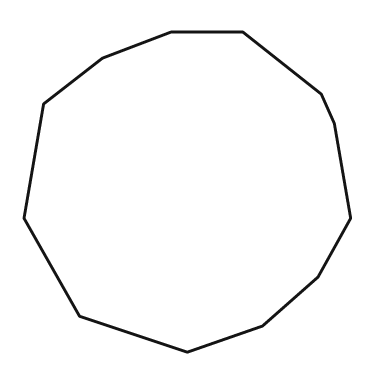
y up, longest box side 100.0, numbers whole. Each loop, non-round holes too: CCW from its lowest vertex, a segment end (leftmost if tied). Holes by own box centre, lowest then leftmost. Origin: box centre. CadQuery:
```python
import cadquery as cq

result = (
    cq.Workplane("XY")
    .moveTo(0.0, -49.0)
    .lineTo(23.0, -41.0)
    .lineTo(40.0, -26.0)
    .lineTo(50.0, -8.0)
    .lineTo(45.0, 21.0)
    .lineTo(41.0, 30.0)
    .lineTo(17.0, 49.0)
    .lineTo(-5.0, 49.0)
    .lineTo(-26.0, 41.0)
    .lineTo(-44.0, 27.0)
    .lineTo(-50.0, -8.0)
    .lineTo(-33.0, -38.0)
    .close()
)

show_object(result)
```